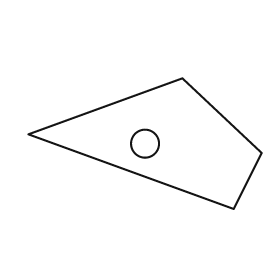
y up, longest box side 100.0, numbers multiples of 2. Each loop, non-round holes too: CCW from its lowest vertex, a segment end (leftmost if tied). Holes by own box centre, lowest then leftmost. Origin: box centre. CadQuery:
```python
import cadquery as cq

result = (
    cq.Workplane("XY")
    .moveTo(38.0, -28.0)
    .lineTo(50.0, -4.0)
    .lineTo(16.0, 28.0)
    .lineTo(-50.0, 4.0)
    .close()
    .moveTo(0.0, 0.0)
    .circle(6.0)
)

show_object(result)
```